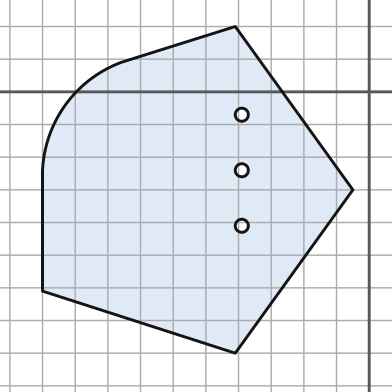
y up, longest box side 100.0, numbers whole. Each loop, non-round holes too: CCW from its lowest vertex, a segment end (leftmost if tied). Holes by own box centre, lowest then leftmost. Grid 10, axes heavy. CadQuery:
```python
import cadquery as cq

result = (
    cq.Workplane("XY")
    .moveTo(-41.0, -80.0)
    .lineTo(-5.0, -30.0)
    .lineTo(-41.0, 20.0)
    .lineTo(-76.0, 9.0)
    .threePointArc((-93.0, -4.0), (-100.0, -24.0))
    .lineTo(-100.0, -61.0)
    .close()
    .moveTo(-39.0, -41.0)
    .circle(2.0)
    .moveTo(-39.0, -24.0)
    .circle(2.0)
    .moveTo(-39.0, -7.0)
    .circle(2.0)
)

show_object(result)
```